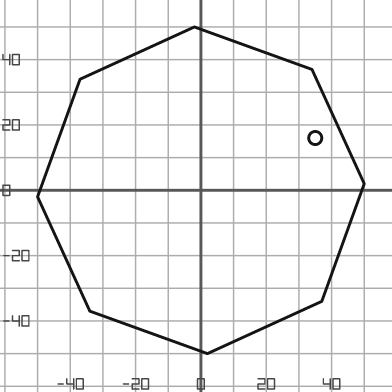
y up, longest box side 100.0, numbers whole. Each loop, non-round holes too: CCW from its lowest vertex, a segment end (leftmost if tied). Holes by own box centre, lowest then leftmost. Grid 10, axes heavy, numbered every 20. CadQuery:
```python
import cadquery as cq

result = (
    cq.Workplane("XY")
    .moveTo(2.0, -50.0)
    .lineTo(37.0, -34.0)
    .lineTo(50.0, 2.0)
    .lineTo(34.0, 37.0)
    .lineTo(-2.0, 50.0)
    .lineTo(-37.0, 34.0)
    .lineTo(-50.0, -2.0)
    .lineTo(-34.0, -37.0)
    .close()
    .moveTo(35.0, 16.0)
    .circle(2.0)
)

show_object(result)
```